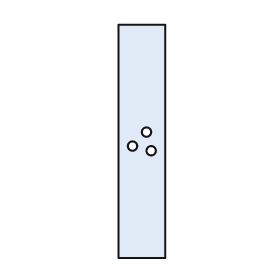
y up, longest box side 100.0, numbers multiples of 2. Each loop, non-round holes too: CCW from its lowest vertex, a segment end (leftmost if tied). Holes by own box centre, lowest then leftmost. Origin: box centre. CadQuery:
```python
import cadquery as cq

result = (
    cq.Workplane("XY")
    .moveTo(-10.0, -50.0)
    .lineTo(10.0, -50.0)
    .lineTo(10.0, 50.0)
    .lineTo(-10.0, 50.0)
    .close()
    .moveTo(4.0, -4.0)
    .circle(2.0)
    .moveTo(-4.0, -2.0)
    .circle(2.0)
    .moveTo(2.0, 4.0)
    .circle(2.0)
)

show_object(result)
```